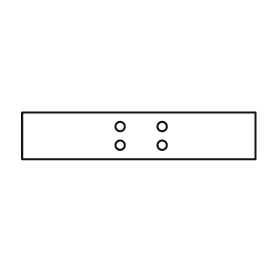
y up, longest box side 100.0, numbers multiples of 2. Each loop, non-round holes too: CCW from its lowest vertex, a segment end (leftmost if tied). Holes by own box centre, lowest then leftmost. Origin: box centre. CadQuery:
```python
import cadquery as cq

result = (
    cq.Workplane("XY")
    .moveTo(-50.0, -10.0)
    .lineTo(50.0, -10.0)
    .lineTo(50.0, 10.0)
    .lineTo(-50.0, 10.0)
    .close()
    .moveTo(-8.0, -4.0)
    .circle(2.0)
    .moveTo(10.0, -4.0)
    .circle(2.0)
    .moveTo(-8.0, 4.0)
    .circle(2.0)
    .moveTo(10.0, 4.0)
    .circle(2.0)
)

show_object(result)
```